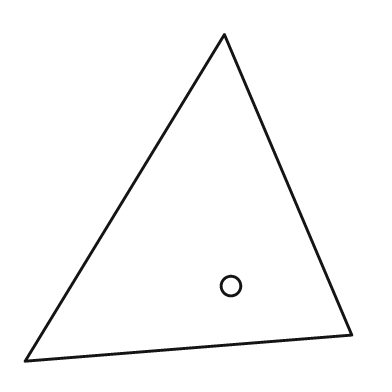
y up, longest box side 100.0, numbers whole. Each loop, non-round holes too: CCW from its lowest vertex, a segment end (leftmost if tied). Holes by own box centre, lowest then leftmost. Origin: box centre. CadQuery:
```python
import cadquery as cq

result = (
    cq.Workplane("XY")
    .moveTo(-50.0, -50.0)
    .lineTo(50.0, -42.0)
    .lineTo(11.0, 50.0)
    .close()
    .moveTo(13.0, -27.0)
    .circle(3.0)
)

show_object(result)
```